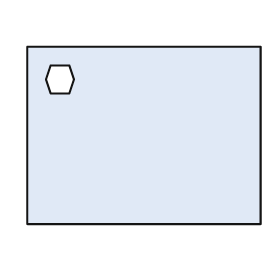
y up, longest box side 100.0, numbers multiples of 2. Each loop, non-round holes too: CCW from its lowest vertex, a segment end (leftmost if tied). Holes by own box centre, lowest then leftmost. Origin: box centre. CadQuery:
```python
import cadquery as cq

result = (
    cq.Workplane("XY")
    .moveTo(-50.0, -38.0)
    .lineTo(50.0, -38.0)
    .lineTo(50.0, 38.0)
    .lineTo(-50.0, 38.0)
    .close()
    .moveTo(-40.0, 18.0)
    .lineTo(-32.0, 18.0)
    .lineTo(-30.0, 24.0)
    .lineTo(-32.0, 30.0)
    .lineTo(-40.0, 30.0)
    .lineTo(-42.0, 24.0)
    .close()
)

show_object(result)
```